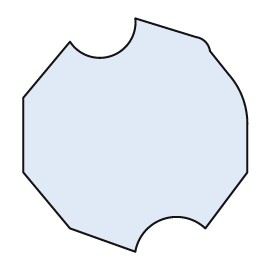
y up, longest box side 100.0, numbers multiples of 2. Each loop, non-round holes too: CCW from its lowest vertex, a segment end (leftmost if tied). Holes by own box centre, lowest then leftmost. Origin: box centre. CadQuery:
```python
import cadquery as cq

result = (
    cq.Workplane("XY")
    .moveTo(0.0, -50.0)
    .threePointArc((12.0, -36.0), (30.0, -40.0))
    .lineTo(48.0, -16.0)
    .lineTo(48.0, 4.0)
    .threePointArc((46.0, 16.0), (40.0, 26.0))
    .lineTo(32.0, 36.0)
    .threePointArc((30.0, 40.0), (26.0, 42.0))
    .lineTo(0.0, 50.0)
    .threePointArc((-10.0, 34.0), (-28.0, 40.0))
    .lineTo(-48.0, 16.0)
    .lineTo(-48.0, -16.0)
    .lineTo(-28.0, -40.0)
    .close()
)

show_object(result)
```